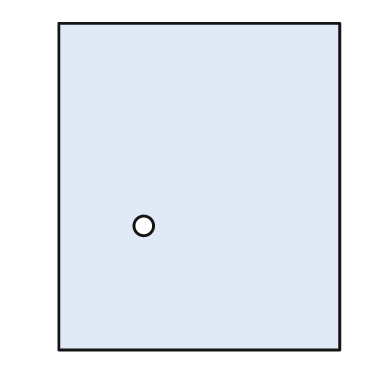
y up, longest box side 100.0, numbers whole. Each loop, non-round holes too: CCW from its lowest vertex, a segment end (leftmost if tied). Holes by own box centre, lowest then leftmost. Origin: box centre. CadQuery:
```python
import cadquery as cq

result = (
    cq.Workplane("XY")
    .moveTo(-43.0, -50.0)
    .lineTo(43.0, -50.0)
    .lineTo(43.0, 50.0)
    .lineTo(-43.0, 50.0)
    .close()
    .moveTo(-17.0, -12.0)
    .circle(3.0)
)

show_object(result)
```